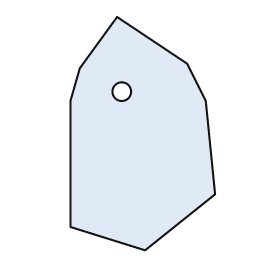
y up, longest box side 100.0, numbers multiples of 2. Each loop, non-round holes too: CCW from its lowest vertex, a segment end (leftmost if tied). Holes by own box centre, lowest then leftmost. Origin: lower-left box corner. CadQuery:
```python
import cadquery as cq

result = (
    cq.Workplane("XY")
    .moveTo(32.0, 0.0)
    .lineTo(62.0, 24.0)
    .lineTo(58.0, 64.0)
    .lineTo(50.0, 80.0)
    .lineTo(20.0, 100.0)
    .lineTo(4.0, 78.0)
    .lineTo(0.0, 64.0)
    .lineTo(0.0, 10.0)
    .close()
    .moveTo(22.0, 68.0)
    .circle(4.0)
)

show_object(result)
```